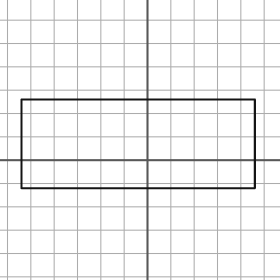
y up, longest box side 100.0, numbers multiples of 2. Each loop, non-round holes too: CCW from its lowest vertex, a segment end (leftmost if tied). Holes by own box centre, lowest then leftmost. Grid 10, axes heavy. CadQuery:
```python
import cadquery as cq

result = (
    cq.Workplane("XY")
    .moveTo(-54.0, -12.0)
    .lineTo(46.0, -12.0)
    .lineTo(46.0, 26.0)
    .lineTo(-54.0, 26.0)
    .close()
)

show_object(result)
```